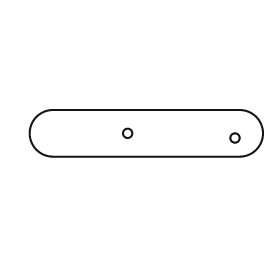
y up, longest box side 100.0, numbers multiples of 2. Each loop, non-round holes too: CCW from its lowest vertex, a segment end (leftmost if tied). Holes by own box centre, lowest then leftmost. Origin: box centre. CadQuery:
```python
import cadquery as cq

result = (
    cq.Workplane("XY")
    .moveTo(-40.0, -10.0)
    .lineTo(40.0, -10.0)
    .threePointArc((50.0, 0.0), (40.0, 10.0))
    .lineTo(-40.0, 10.0)
    .threePointArc((-50.0, 0.0), (-40.0, -10.0))
    .close()
    .moveTo(38.0, -2.0)
    .circle(2.0)
    .moveTo(-8.0, 0.0)
    .circle(2.0)
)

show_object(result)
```